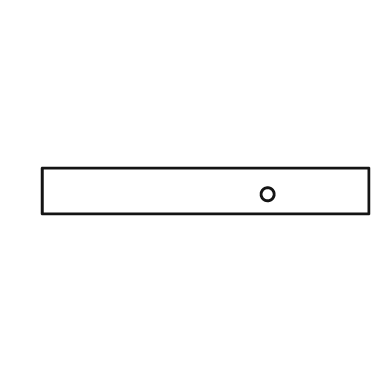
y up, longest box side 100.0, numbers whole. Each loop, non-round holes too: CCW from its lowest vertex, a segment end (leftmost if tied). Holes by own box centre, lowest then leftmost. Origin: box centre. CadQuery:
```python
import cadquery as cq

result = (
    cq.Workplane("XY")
    .moveTo(-50.0, -7.0)
    .lineTo(50.0, -7.0)
    .lineTo(50.0, 7.0)
    .lineTo(-50.0, 7.0)
    .close()
    .moveTo(19.0, -1.0)
    .circle(2.0)
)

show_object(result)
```